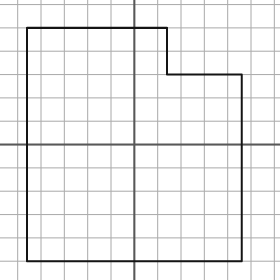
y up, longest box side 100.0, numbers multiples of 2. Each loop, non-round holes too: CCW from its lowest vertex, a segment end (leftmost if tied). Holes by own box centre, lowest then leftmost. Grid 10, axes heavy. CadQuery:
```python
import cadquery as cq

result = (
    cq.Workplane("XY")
    .moveTo(-46.0, -50.0)
    .lineTo(46.0, -50.0)
    .lineTo(46.0, 30.0)
    .lineTo(14.0, 30.0)
    .lineTo(14.0, 50.0)
    .lineTo(-46.0, 50.0)
    .close()
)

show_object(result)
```